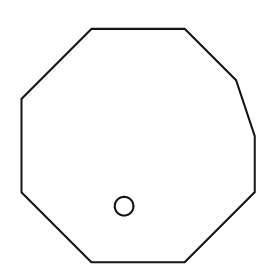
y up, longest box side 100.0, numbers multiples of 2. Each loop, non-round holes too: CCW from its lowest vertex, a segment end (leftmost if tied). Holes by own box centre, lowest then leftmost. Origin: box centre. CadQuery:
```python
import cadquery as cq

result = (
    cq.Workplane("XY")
    .moveTo(-20.0, -50.0)
    .lineTo(20.0, -50.0)
    .lineTo(50.0, -20.0)
    .lineTo(50.0, 4.0)
    .lineTo(42.0, 28.0)
    .lineTo(20.0, 50.0)
    .lineTo(-20.0, 50.0)
    .lineTo(-50.0, 20.0)
    .lineTo(-50.0, -20.0)
    .close()
    .moveTo(-6.0, -26.0)
    .circle(4.0)
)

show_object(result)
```